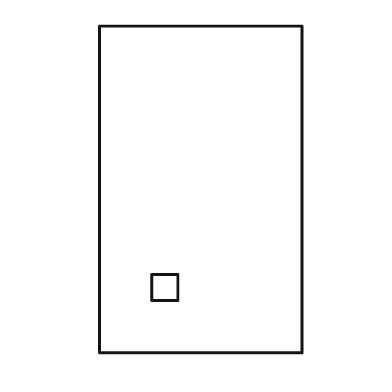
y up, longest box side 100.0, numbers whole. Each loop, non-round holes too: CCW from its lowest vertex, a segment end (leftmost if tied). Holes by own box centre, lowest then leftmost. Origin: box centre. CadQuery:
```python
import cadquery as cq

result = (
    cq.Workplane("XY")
    .moveTo(-31.0, -50.0)
    .lineTo(31.0, -50.0)
    .lineTo(31.0, 50.0)
    .lineTo(-31.0, 50.0)
    .close()
    .moveTo(-15.0, -34.0)
    .lineTo(-7.0, -34.0)
    .lineTo(-7.0, -26.0)
    .lineTo(-15.0, -26.0)
    .close()
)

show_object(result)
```